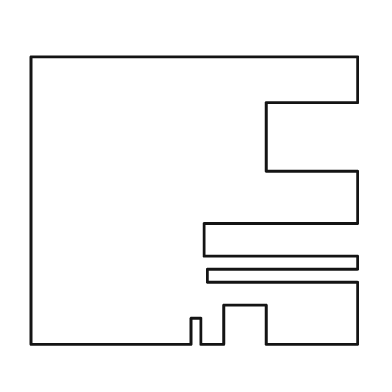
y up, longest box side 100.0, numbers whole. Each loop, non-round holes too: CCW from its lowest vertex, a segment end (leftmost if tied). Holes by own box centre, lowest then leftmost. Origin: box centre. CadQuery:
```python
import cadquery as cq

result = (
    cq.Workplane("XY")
    .moveTo(-50.0, -44.0)
    .lineTo(-1.0, -44.0)
    .lineTo(-1.0, -36.0)
    .lineTo(2.0, -36.0)
    .lineTo(2.0, -44.0)
    .lineTo(9.0, -44.0)
    .lineTo(9.0, -32.0)
    .lineTo(22.0, -32.0)
    .lineTo(22.0, -44.0)
    .lineTo(50.0, -44.0)
    .lineTo(50.0, -25.0)
    .lineTo(4.0, -25.0)
    .lineTo(4.0, -21.0)
    .lineTo(50.0, -21.0)
    .lineTo(50.0, -17.0)
    .lineTo(3.0, -17.0)
    .lineTo(3.0, -7.0)
    .lineTo(50.0, -7.0)
    .lineTo(50.0, 9.0)
    .lineTo(22.0, 9.0)
    .lineTo(22.0, 30.0)
    .lineTo(50.0, 30.0)
    .lineTo(50.0, 44.0)
    .lineTo(-50.0, 44.0)
    .close()
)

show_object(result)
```